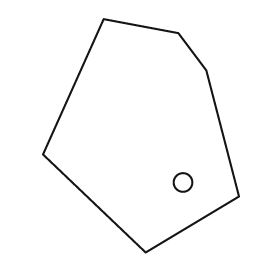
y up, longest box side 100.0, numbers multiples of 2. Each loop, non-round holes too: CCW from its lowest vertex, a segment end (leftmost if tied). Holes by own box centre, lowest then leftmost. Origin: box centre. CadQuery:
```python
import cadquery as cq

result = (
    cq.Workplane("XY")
    .moveTo(2.0, -50.0)
    .lineTo(42.0, -26.0)
    .lineTo(28.0, 28.0)
    .lineTo(16.0, 44.0)
    .lineTo(-16.0, 50.0)
    .lineTo(-42.0, -8.0)
    .close()
    .moveTo(18.0, -20.0)
    .circle(4.0)
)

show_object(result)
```